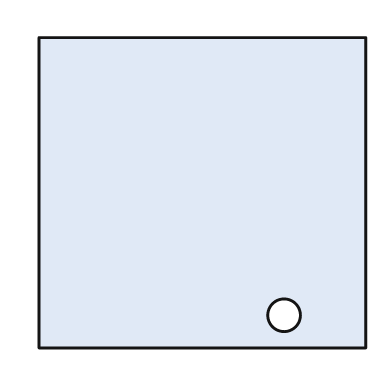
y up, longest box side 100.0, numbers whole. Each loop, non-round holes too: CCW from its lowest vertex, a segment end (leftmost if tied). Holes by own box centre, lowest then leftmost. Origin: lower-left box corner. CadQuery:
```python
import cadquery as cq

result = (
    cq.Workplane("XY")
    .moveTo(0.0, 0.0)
    .lineTo(100.0, 0.0)
    .lineTo(100.0, 95.0)
    .lineTo(0.0, 95.0)
    .close()
    .moveTo(75.0, 10.0)
    .circle(5.0)
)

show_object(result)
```